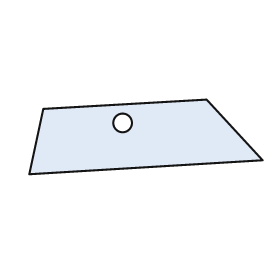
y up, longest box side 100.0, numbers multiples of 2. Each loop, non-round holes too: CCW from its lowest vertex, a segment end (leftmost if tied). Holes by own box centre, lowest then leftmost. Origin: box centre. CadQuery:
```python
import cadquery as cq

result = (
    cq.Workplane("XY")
    .moveTo(-50.0, -16.0)
    .lineTo(50.0, -10.0)
    .lineTo(26.0, 16.0)
    .lineTo(-44.0, 12.0)
    .close()
    .moveTo(-10.0, 6.0)
    .circle(4.0)
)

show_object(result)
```